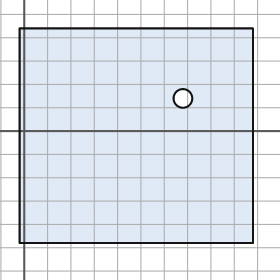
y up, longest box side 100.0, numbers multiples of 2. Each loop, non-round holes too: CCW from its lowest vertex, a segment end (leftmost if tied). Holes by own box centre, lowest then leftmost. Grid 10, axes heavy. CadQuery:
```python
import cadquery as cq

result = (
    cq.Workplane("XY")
    .moveTo(-2.0, -48.0)
    .lineTo(98.0, -48.0)
    .lineTo(98.0, 44.0)
    .lineTo(-2.0, 44.0)
    .close()
    .moveTo(68.0, 14.0)
    .circle(4.0)
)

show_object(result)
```